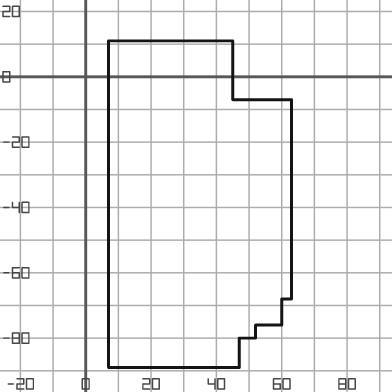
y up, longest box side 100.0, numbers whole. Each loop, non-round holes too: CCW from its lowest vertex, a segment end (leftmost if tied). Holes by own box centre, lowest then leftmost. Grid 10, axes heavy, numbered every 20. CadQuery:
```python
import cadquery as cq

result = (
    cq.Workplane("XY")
    .moveTo(7.0, -89.0)
    .lineTo(47.0, -89.0)
    .lineTo(47.0, -80.0)
    .lineTo(52.0, -80.0)
    .lineTo(52.0, -76.0)
    .lineTo(60.0, -76.0)
    .lineTo(60.0, -68.0)
    .lineTo(63.0, -68.0)
    .lineTo(63.0, -7.0)
    .lineTo(45.0, -7.0)
    .lineTo(45.0, 11.0)
    .lineTo(7.0, 11.0)
    .close()
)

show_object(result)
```